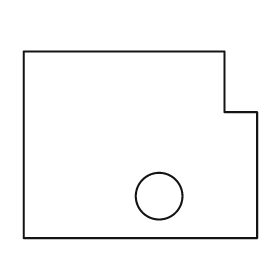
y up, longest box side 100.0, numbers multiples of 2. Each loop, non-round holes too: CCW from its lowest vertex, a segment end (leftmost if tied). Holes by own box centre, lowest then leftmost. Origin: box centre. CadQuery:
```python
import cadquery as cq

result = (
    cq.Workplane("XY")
    .moveTo(-50.0, -40.0)
    .lineTo(50.0, -40.0)
    .lineTo(50.0, 14.0)
    .lineTo(36.0, 14.0)
    .lineTo(36.0, 40.0)
    .lineTo(-50.0, 40.0)
    .close()
    .moveTo(8.0, -22.0)
    .circle(10.0)
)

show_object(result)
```